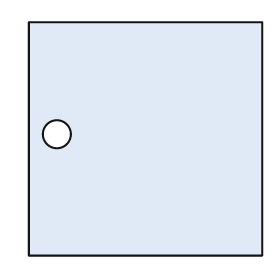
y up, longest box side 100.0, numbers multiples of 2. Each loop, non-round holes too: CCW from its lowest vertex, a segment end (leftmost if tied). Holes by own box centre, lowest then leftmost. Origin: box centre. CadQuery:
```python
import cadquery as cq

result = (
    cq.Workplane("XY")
    .moveTo(-50.0, -50.0)
    .lineTo(50.0, -50.0)
    .lineTo(50.0, 50.0)
    .lineTo(-50.0, 50.0)
    .close()
    .moveTo(-38.0, 2.0)
    .circle(6.0)
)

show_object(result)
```